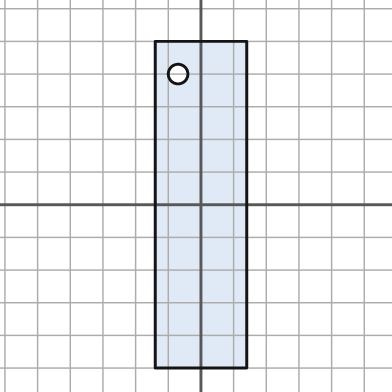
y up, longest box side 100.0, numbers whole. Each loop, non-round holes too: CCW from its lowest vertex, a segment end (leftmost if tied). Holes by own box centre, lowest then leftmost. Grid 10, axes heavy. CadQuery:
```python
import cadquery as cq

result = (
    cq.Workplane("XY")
    .moveTo(-14.0, -50.0)
    .lineTo(14.0, -50.0)
    .lineTo(14.0, 50.0)
    .lineTo(-14.0, 50.0)
    .close()
    .moveTo(-7.0, 40.0)
    .circle(3.0)
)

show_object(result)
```